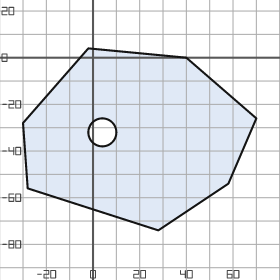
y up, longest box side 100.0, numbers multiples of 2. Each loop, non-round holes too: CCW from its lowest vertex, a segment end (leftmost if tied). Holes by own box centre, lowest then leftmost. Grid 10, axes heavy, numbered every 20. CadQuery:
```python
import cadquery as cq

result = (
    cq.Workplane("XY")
    .moveTo(28.0, -74.0)
    .lineTo(58.0, -54.0)
    .lineTo(70.0, -26.0)
    .lineTo(40.0, 0.0)
    .lineTo(-2.0, 4.0)
    .lineTo(-30.0, -28.0)
    .lineTo(-28.0, -56.0)
    .close()
    .moveTo(4.0, -32.0)
    .circle(6.0)
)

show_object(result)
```